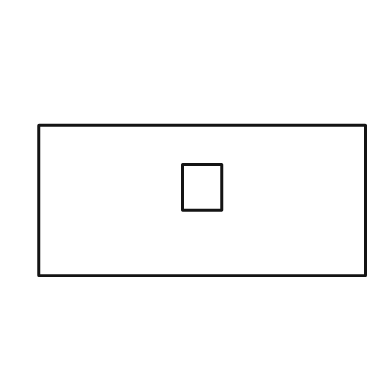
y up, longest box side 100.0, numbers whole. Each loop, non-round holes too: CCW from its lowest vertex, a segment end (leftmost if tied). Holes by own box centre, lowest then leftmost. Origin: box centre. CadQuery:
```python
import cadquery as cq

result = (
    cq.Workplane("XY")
    .moveTo(-50.0, -23.0)
    .lineTo(50.0, -23.0)
    .lineTo(50.0, 23.0)
    .lineTo(-50.0, 23.0)
    .close()
    .moveTo(-6.0, -3.0)
    .lineTo(6.0, -3.0)
    .lineTo(6.0, 11.0)
    .lineTo(-6.0, 11.0)
    .close()
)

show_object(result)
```